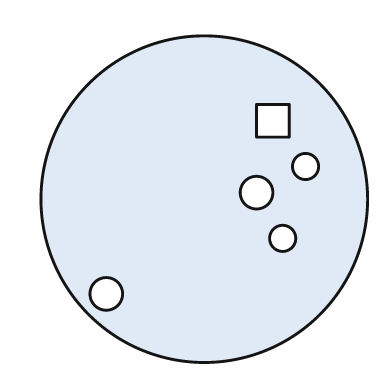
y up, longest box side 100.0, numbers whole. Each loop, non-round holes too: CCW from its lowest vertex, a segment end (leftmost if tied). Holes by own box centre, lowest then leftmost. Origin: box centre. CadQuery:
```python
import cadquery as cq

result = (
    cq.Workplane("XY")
    .moveTo(0.0, 0.0)
    .circle(50.0)
    .moveTo(-30.0, -29.0)
    .circle(5.0)
    .moveTo(24.0, -12.0)
    .circle(4.0)
    .moveTo(16.0, 2.0)
    .circle(5.0)
    .moveTo(31.0, 10.0)
    .circle(4.0)
    .moveTo(16.0, 19.0)
    .lineTo(26.0, 19.0)
    .lineTo(26.0, 29.0)
    .lineTo(16.0, 29.0)
    .close()
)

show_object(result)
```